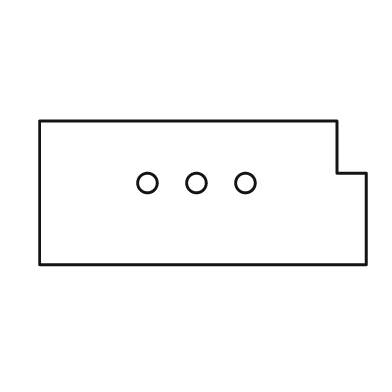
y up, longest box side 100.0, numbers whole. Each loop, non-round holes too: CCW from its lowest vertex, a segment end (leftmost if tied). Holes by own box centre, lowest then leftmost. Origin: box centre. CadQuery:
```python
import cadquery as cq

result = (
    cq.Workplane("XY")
    .moveTo(-50.0, -22.0)
    .lineTo(50.0, -22.0)
    .lineTo(50.0, 6.0)
    .lineTo(41.0, 6.0)
    .lineTo(41.0, 22.0)
    .lineTo(-50.0, 22.0)
    .close()
    .moveTo(-17.0, 3.0)
    .circle(3.0)
    .moveTo(-2.0, 3.0)
    .circle(3.0)
    .moveTo(13.0, 3.0)
    .circle(3.0)
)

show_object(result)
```